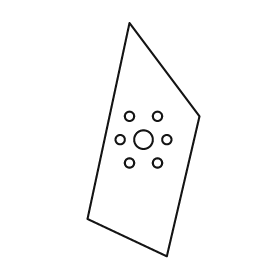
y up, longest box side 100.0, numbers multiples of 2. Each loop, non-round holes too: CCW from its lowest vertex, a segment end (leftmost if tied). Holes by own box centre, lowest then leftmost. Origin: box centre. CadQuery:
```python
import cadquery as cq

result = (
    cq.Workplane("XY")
    .moveTo(10.0, -50.0)
    .lineTo(24.0, 10.0)
    .lineTo(-6.0, 50.0)
    .lineTo(-24.0, -34.0)
    .close()
    .moveTo(-6.0, -10.0)
    .circle(2.0)
    .moveTo(6.0, -10.0)
    .circle(2.0)
    .moveTo(-10.0, 0.0)
    .circle(2.0)
    .moveTo(0.0, 0.0)
    .circle(4.0)
    .moveTo(10.0, 0.0)
    .circle(2.0)
    .moveTo(-6.0, 10.0)
    .circle(2.0)
    .moveTo(6.0, 10.0)
    .circle(2.0)
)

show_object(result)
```